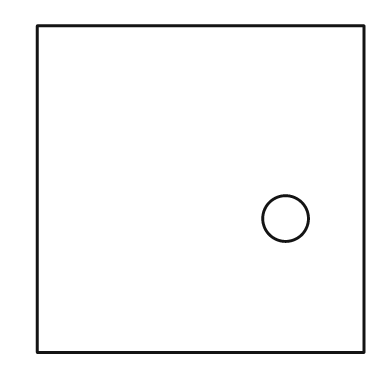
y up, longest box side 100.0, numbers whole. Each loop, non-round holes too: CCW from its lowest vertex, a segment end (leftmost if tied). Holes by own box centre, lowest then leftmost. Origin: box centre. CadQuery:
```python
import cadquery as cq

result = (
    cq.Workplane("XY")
    .moveTo(-50.0, -50.0)
    .lineTo(50.0, -50.0)
    .lineTo(50.0, 50.0)
    .lineTo(-50.0, 50.0)
    .close()
    .moveTo(26.0, -9.0)
    .circle(7.0)
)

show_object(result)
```